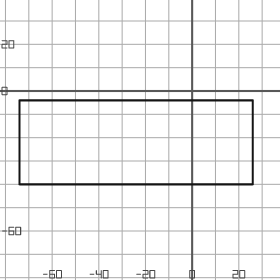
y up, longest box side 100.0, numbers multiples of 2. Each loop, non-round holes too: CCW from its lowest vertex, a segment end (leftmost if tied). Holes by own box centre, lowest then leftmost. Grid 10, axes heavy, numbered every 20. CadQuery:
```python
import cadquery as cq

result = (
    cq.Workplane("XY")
    .moveTo(-74.0, -40.0)
    .lineTo(26.0, -40.0)
    .lineTo(26.0, -4.0)
    .lineTo(-74.0, -4.0)
    .close()
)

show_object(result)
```